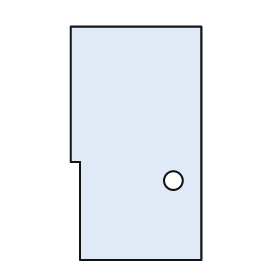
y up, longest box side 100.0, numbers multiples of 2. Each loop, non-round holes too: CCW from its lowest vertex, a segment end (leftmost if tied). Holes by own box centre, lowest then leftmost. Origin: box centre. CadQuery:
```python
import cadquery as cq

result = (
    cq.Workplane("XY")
    .moveTo(-24.0, -50.0)
    .lineTo(28.0, -50.0)
    .lineTo(28.0, 50.0)
    .lineTo(-28.0, 50.0)
    .lineTo(-28.0, -8.0)
    .lineTo(-24.0, -8.0)
    .close()
    .moveTo(16.0, -16.0)
    .circle(4.0)
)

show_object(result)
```